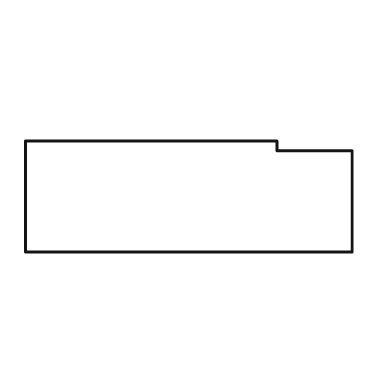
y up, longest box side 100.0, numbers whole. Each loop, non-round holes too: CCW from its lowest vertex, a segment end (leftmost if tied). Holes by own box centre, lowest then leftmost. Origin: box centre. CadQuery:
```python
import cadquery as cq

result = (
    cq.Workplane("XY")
    .moveTo(-50.0, -17.0)
    .lineTo(50.0, -17.0)
    .lineTo(50.0, 14.0)
    .lineTo(27.0, 14.0)
    .lineTo(27.0, 17.0)
    .lineTo(-50.0, 17.0)
    .close()
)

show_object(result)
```